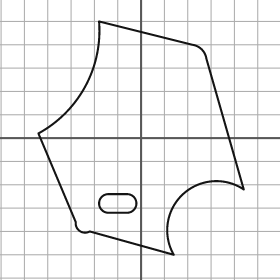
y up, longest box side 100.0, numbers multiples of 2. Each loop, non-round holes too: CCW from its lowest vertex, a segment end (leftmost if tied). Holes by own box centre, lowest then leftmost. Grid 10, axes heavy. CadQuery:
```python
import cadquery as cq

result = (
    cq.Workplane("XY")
    .moveTo(14.0, -50.0)
    .threePointArc((18.0, -24.0), (44.0, -22.0))
    .lineTo(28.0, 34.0)
    .threePointArc((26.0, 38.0), (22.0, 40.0))
    .lineTo(-18.0, 50.0)
    .threePointArc((-24.0, 22.0), (-44.0, 2.0))
    .lineTo(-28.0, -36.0)
    .threePointArc((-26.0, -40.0), (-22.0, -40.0))
    .close()
    .moveTo(-14.0, -32.0)
    .lineTo(-6.0, -32.0)
    .threePointArc((-2.0, -28.0), (-6.0, -24.0))
    .lineTo(-14.0, -24.0)
    .threePointArc((-18.0, -28.0), (-14.0, -32.0))
    .close()
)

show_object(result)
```